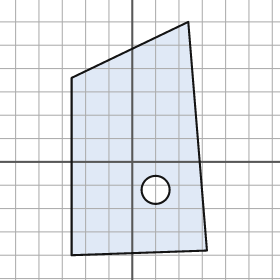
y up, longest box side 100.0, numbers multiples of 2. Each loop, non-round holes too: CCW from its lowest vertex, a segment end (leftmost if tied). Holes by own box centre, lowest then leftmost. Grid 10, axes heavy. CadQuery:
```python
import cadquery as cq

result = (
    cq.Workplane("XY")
    .moveTo(-26.0, -40.0)
    .lineTo(32.0, -38.0)
    .lineTo(24.0, 60.0)
    .lineTo(-26.0, 36.0)
    .close()
    .moveTo(10.0, -12.0)
    .circle(6.0)
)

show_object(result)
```